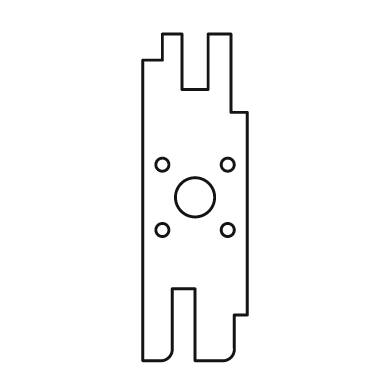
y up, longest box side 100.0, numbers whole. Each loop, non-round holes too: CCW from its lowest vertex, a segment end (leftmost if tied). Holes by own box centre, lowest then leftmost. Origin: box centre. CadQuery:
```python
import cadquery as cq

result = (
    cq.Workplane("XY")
    .moveTo(-16.0, -50.0)
    .lineTo(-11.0, -50.0)
    .threePointArc((-8.0, -49.0), (-7.0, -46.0))
    .lineTo(-7.0, -28.0)
    .lineTo(0.0, -28.0)
    .lineTo(0.0, -50.0)
    .lineTo(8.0, -50.0)
    .threePointArc((11.0, -49.0), (12.0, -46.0))
    .lineTo(12.0, -36.0)
    .lineTo(16.0, -36.0)
    .lineTo(16.0, 26.0)
    .lineTo(11.0, 26.0)
    .lineTo(11.0, 50.0)
    .lineTo(4.0, 50.0)
    .lineTo(4.0, 33.0)
    .lineTo(-4.0, 33.0)
    .lineTo(-4.0, 50.0)
    .lineTo(-10.0, 50.0)
    .lineTo(-10.0, 42.0)
    .lineTo(-16.0, 42.0)
    .close()
    .moveTo(-10.0, -10.0)
    .circle(2.0)
    .moveTo(10.0, -10.0)
    .circle(2.0)
    .moveTo(0.0, 0.0)
    .circle(6.0)
    .moveTo(-10.0, 10.0)
    .circle(2.0)
    .moveTo(10.0, 10.0)
    .circle(2.0)
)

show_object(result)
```